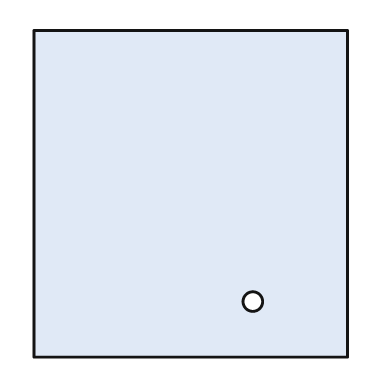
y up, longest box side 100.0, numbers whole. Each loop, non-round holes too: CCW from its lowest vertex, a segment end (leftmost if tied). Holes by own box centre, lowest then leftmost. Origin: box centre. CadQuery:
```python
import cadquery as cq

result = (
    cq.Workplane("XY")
    .moveTo(-48.0, -50.0)
    .lineTo(48.0, -50.0)
    .lineTo(48.0, 50.0)
    .lineTo(-48.0, 50.0)
    .close()
    .moveTo(19.0, -33.0)
    .circle(3.0)
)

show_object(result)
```